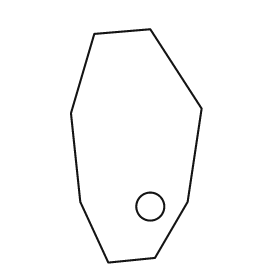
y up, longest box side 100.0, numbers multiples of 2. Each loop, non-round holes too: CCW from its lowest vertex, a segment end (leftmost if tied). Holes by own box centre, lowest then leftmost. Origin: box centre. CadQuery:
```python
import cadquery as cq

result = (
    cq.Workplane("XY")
    .moveTo(-12.0, -50.0)
    .lineTo(8.0, -48.0)
    .lineTo(22.0, -24.0)
    .lineTo(28.0, 16.0)
    .lineTo(6.0, 50.0)
    .lineTo(-18.0, 48.0)
    .lineTo(-28.0, 14.0)
    .lineTo(-24.0, -24.0)
    .close()
    .moveTo(6.0, -26.0)
    .circle(6.0)
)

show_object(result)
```